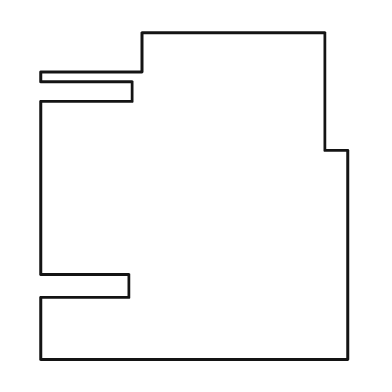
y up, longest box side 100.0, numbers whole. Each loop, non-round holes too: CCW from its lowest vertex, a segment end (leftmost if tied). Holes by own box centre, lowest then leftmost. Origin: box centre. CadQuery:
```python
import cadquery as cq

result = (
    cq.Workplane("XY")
    .moveTo(-47.0, -50.0)
    .lineTo(47.0, -50.0)
    .lineTo(47.0, 14.0)
    .lineTo(40.0, 14.0)
    .lineTo(40.0, 50.0)
    .lineTo(-16.0, 50.0)
    .lineTo(-16.0, 38.0)
    .lineTo(-47.0, 38.0)
    .lineTo(-47.0, 35.0)
    .lineTo(-19.0, 35.0)
    .lineTo(-19.0, 29.0)
    .lineTo(-47.0, 29.0)
    .lineTo(-47.0, -24.0)
    .lineTo(-20.0, -24.0)
    .lineTo(-20.0, -31.0)
    .lineTo(-47.0, -31.0)
    .close()
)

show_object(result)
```